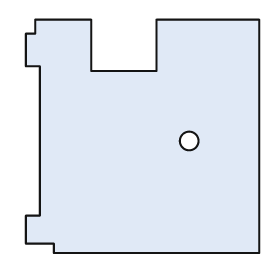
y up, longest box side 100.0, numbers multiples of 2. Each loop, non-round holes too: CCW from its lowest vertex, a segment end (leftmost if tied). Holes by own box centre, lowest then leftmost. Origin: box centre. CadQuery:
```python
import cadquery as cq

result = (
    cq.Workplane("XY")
    .moveTo(-38.0, -50.0)
    .lineTo(50.0, -50.0)
    .lineTo(50.0, 50.0)
    .lineTo(6.0, 50.0)
    .lineTo(6.0, 28.0)
    .lineTo(-22.0, 28.0)
    .lineTo(-22.0, 50.0)
    .lineTo(-46.0, 50.0)
    .lineTo(-46.0, 44.0)
    .lineTo(-50.0, 44.0)
    .lineTo(-50.0, 30.0)
    .lineTo(-44.0, 30.0)
    .lineTo(-44.0, -34.0)
    .lineTo(-50.0, -34.0)
    .lineTo(-50.0, -46.0)
    .lineTo(-38.0, -46.0)
    .close()
    .moveTo(20.0, -2.0)
    .circle(4.0)
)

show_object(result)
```